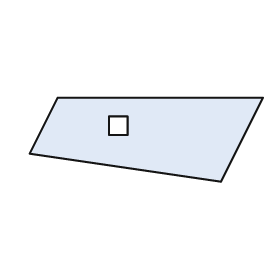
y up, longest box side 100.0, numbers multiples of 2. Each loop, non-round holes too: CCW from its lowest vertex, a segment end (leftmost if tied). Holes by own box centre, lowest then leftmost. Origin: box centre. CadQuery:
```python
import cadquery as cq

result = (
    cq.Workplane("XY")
    .moveTo(32.0, -18.0)
    .lineTo(50.0, 18.0)
    .lineTo(-38.0, 18.0)
    .lineTo(-50.0, -6.0)
    .close()
    .moveTo(-16.0, 2.0)
    .lineTo(-8.0, 2.0)
    .lineTo(-8.0, 10.0)
    .lineTo(-16.0, 10.0)
    .close()
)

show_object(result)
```